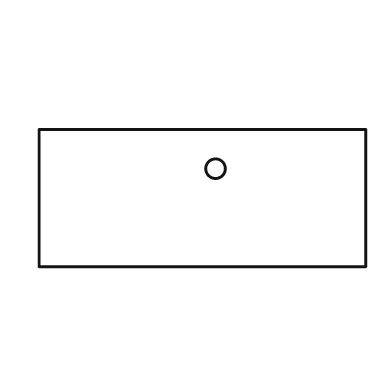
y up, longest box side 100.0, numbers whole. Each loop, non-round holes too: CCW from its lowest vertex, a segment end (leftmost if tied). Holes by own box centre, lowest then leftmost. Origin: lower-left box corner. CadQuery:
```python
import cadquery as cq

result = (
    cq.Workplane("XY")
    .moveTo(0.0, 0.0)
    .lineTo(100.0, 0.0)
    .lineTo(100.0, 42.0)
    .lineTo(0.0, 42.0)
    .close()
    .moveTo(54.0, 30.0)
    .circle(3.0)
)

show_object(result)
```